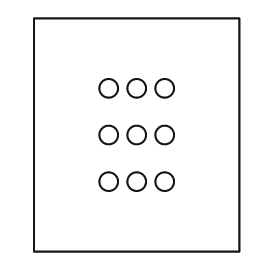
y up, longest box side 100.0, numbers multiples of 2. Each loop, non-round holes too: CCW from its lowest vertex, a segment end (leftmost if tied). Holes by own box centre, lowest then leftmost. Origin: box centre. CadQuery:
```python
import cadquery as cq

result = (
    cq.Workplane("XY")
    .moveTo(-44.0, -50.0)
    .lineTo(44.0, -50.0)
    .lineTo(44.0, 50.0)
    .lineTo(-44.0, 50.0)
    .close()
    .moveTo(-12.0, -20.0)
    .circle(4.0)
    .moveTo(0.0, -20.0)
    .circle(4.0)
    .moveTo(12.0, -20.0)
    .circle(4.0)
    .moveTo(-12.0, 0.0)
    .circle(4.0)
    .moveTo(0.0, 0.0)
    .circle(4.0)
    .moveTo(12.0, 0.0)
    .circle(4.0)
    .moveTo(-12.0, 20.0)
    .circle(4.0)
    .moveTo(0.0, 20.0)
    .circle(4.0)
    .moveTo(12.0, 20.0)
    .circle(4.0)
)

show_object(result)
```